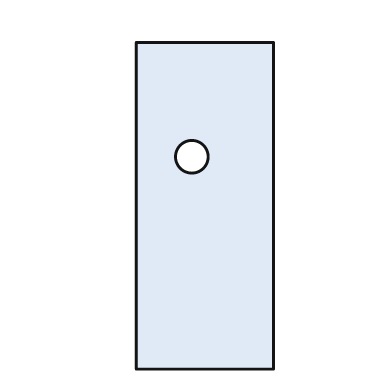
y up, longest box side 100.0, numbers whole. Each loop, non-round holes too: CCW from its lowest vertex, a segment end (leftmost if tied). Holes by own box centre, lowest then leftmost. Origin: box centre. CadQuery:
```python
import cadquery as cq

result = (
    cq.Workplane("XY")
    .moveTo(-21.0, -50.0)
    .lineTo(21.0, -50.0)
    .lineTo(21.0, 50.0)
    .lineTo(-21.0, 50.0)
    .close()
    .moveTo(-4.0, 15.0)
    .circle(5.0)
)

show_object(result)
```